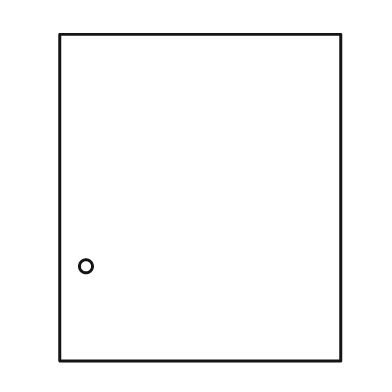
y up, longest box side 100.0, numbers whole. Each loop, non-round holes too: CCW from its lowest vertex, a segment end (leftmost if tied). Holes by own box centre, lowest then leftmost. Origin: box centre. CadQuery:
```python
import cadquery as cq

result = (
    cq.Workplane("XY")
    .moveTo(-43.0, -50.0)
    .lineTo(43.0, -50.0)
    .lineTo(43.0, 50.0)
    .lineTo(-43.0, 50.0)
    .close()
    .moveTo(-35.0, -21.0)
    .circle(2.0)
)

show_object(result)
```